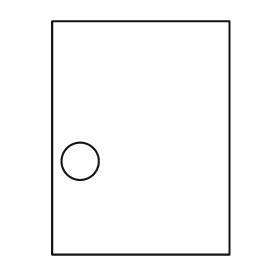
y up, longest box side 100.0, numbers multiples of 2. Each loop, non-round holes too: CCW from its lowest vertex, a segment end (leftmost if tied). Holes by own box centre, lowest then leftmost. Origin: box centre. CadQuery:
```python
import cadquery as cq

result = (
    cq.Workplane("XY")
    .moveTo(-38.0, -50.0)
    .lineTo(38.0, -50.0)
    .lineTo(38.0, 50.0)
    .lineTo(-38.0, 50.0)
    .close()
    .moveTo(-26.0, -10.0)
    .circle(8.0)
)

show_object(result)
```